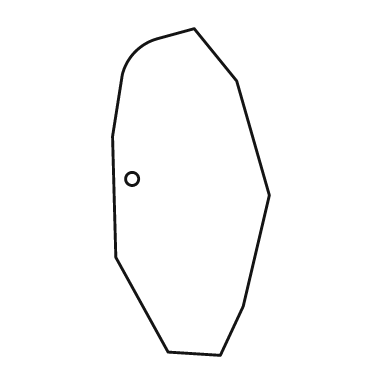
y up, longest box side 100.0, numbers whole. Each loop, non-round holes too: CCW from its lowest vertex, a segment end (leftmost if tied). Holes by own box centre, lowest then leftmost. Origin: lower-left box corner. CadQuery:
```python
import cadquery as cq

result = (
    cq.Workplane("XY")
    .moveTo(33.0, 0.0)
    .lineTo(40.0, 15.0)
    .lineTo(48.0, 49.0)
    .lineTo(38.0, 84.0)
    .lineTo(25.0, 100.0)
    .lineTo(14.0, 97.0)
    .threePointArc((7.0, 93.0), (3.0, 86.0))
    .lineTo(0.0, 67.0)
    .lineTo(1.0, 30.0)
    .lineTo(17.0, 1.0)
    .close()
    .moveTo(6.0, 54.0)
    .circle(2.0)
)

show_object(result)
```